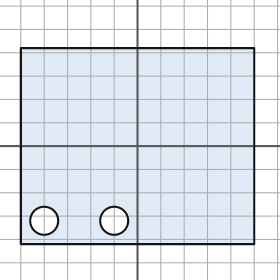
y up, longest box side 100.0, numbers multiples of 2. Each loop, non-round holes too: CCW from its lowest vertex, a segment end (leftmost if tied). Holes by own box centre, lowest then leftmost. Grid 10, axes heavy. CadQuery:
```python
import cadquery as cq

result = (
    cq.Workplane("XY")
    .moveTo(-50.0, -42.0)
    .lineTo(50.0, -42.0)
    .lineTo(50.0, 42.0)
    .lineTo(-50.0, 42.0)
    .close()
    .moveTo(-40.0, -32.0)
    .circle(6.0)
    .moveTo(-10.0, -32.0)
    .circle(6.0)
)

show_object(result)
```